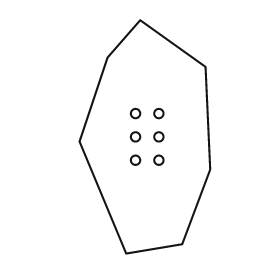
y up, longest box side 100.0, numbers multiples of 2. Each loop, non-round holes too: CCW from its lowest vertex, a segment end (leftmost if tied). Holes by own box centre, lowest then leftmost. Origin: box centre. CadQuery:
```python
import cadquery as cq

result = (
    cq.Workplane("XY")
    .moveTo(-8.0, -50.0)
    .lineTo(16.0, -46.0)
    .lineTo(28.0, -14.0)
    .lineTo(26.0, 30.0)
    .lineTo(-2.0, 50.0)
    .lineTo(-16.0, 34.0)
    .lineTo(-28.0, -2.0)
    .close()
    .moveTo(-4.0, -10.0)
    .circle(2.0)
    .moveTo(6.0, -10.0)
    .circle(2.0)
    .moveTo(-4.0, 0.0)
    .circle(2.0)
    .moveTo(6.0, 0.0)
    .circle(2.0)
    .moveTo(-4.0, 10.0)
    .circle(2.0)
    .moveTo(6.0, 10.0)
    .circle(2.0)
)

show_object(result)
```